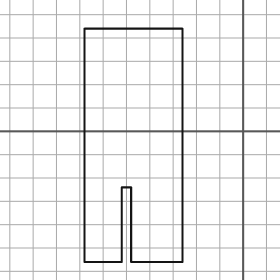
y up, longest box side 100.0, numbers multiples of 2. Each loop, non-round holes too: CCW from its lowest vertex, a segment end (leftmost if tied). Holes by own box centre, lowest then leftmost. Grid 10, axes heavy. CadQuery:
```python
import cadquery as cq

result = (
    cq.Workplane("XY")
    .moveTo(-68.0, -56.0)
    .lineTo(-52.0, -56.0)
    .lineTo(-52.0, -24.0)
    .lineTo(-48.0, -24.0)
    .lineTo(-48.0, -56.0)
    .lineTo(-26.0, -56.0)
    .lineTo(-26.0, 44.0)
    .lineTo(-68.0, 44.0)
    .close()
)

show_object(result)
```